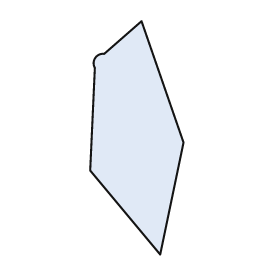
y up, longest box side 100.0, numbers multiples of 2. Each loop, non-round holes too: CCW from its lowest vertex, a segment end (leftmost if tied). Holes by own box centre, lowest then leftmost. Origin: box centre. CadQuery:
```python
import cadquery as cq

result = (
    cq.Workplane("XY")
    .moveTo(10.0, -50.0)
    .lineTo(20.0, -2.0)
    .lineTo(2.0, 50.0)
    .lineTo(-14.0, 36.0)
    .threePointArc((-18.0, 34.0), (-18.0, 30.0))
    .lineTo(-20.0, -14.0)
    .close()
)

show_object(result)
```